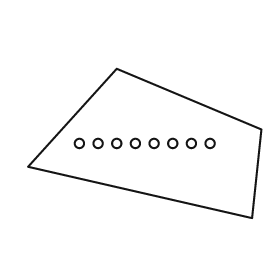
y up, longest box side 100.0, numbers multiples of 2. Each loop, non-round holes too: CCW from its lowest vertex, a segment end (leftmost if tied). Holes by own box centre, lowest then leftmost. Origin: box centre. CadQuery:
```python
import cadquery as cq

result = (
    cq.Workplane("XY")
    .moveTo(46.0, -32.0)
    .lineTo(50.0, 6.0)
    .lineTo(-12.0, 32.0)
    .lineTo(-50.0, -10.0)
    .close()
    .moveTo(-28.0, 0.0)
    .circle(2.0)
    .moveTo(-20.0, 0.0)
    .circle(2.0)
    .moveTo(-12.0, 0.0)
    .circle(2.0)
    .moveTo(-4.0, 0.0)
    .circle(2.0)
    .moveTo(4.0, 0.0)
    .circle(2.0)
    .moveTo(12.0, 0.0)
    .circle(2.0)
    .moveTo(20.0, 0.0)
    .circle(2.0)
    .moveTo(28.0, 0.0)
    .circle(2.0)
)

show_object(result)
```